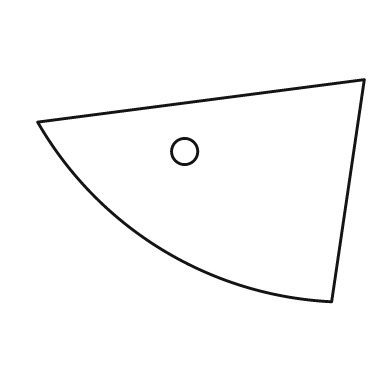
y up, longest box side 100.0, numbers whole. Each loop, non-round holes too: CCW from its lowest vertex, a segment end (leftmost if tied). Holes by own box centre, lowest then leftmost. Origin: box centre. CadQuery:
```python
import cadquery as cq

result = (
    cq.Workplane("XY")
    .moveTo(40.0, -34.0)
    .lineTo(50.0, 34.0)
    .lineTo(-50.0, 21.0)
    .threePointArc((-12.0, -18.0), (40.0, -34.0))
    .close()
    .moveTo(-5.0, 12.0)
    .circle(4.0)
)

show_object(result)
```